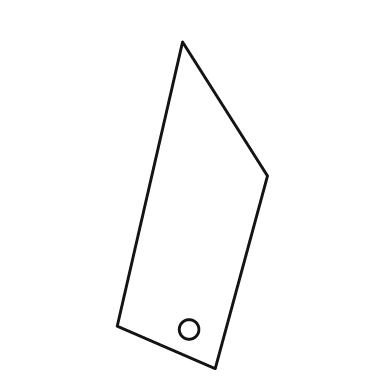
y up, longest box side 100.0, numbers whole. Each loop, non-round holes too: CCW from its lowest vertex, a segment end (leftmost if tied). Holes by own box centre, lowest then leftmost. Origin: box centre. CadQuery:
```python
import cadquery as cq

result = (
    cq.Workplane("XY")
    .moveTo(7.0, -50.0)
    .lineTo(23.0, 9.0)
    .lineTo(-3.0, 50.0)
    .lineTo(-23.0, -37.0)
    .close()
    .moveTo(-1.0, -38.0)
    .circle(3.0)
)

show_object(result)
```